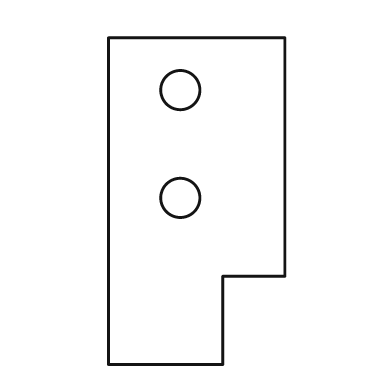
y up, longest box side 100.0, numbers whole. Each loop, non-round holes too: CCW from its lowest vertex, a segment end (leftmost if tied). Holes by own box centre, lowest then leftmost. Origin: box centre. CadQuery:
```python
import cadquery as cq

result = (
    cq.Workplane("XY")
    .moveTo(-27.0, -50.0)
    .lineTo(8.0, -50.0)
    .lineTo(8.0, -23.0)
    .lineTo(27.0, -23.0)
    .lineTo(27.0, 50.0)
    .lineTo(-27.0, 50.0)
    .close()
    .moveTo(-5.0, 1.0)
    .circle(6.0)
    .moveTo(-5.0, 34.0)
    .circle(6.0)
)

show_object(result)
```